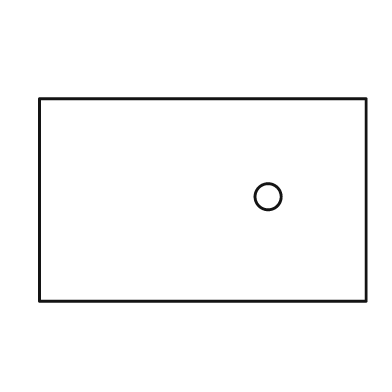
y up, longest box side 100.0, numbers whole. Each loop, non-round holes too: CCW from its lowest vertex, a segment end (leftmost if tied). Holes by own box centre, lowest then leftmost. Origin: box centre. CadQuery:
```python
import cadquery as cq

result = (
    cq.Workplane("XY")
    .moveTo(-50.0, -31.0)
    .lineTo(50.0, -31.0)
    .lineTo(50.0, 31.0)
    .lineTo(-50.0, 31.0)
    .close()
    .moveTo(20.0, 1.0)
    .circle(4.0)
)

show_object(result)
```